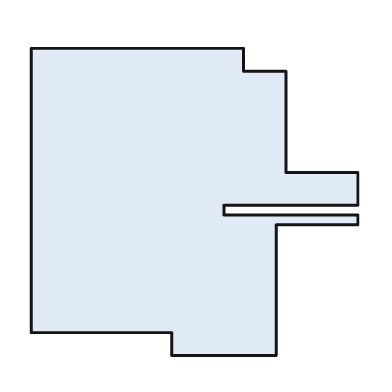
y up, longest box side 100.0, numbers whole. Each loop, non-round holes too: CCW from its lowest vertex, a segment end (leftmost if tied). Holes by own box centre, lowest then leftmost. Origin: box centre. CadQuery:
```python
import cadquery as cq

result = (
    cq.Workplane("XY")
    .moveTo(-7.0, -47.0)
    .lineTo(25.0, -47.0)
    .lineTo(25.0, -7.0)
    .lineTo(50.0, -7.0)
    .lineTo(50.0, -4.0)
    .lineTo(9.0, -4.0)
    .lineTo(9.0, -1.0)
    .lineTo(50.0, -1.0)
    .lineTo(50.0, 9.0)
    .lineTo(28.0, 9.0)
    .lineTo(28.0, 40.0)
    .lineTo(15.0, 40.0)
    .lineTo(15.0, 47.0)
    .lineTo(-50.0, 47.0)
    .lineTo(-50.0, -40.0)
    .lineTo(-7.0, -40.0)
    .close()
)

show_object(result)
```